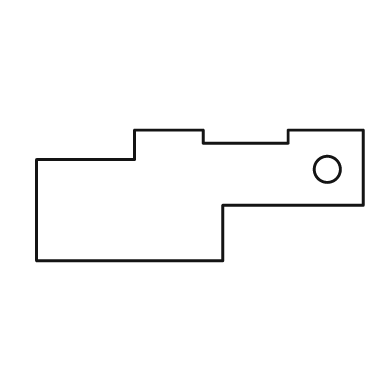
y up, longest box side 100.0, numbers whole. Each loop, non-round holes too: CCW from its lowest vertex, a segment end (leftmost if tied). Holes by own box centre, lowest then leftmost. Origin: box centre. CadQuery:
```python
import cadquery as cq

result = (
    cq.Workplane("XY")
    .moveTo(-50.0, -20.0)
    .lineTo(7.0, -20.0)
    .lineTo(7.0, -3.0)
    .lineTo(50.0, -3.0)
    .lineTo(50.0, 20.0)
    .lineTo(27.0, 20.0)
    .lineTo(27.0, 16.0)
    .lineTo(1.0, 16.0)
    .lineTo(1.0, 20.0)
    .lineTo(-20.0, 20.0)
    .lineTo(-20.0, 11.0)
    .lineTo(-50.0, 11.0)
    .close()
    .moveTo(39.0, 8.0)
    .circle(4.0)
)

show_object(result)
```